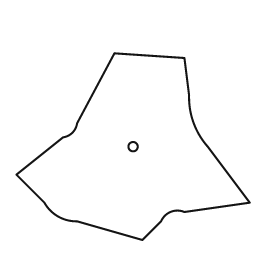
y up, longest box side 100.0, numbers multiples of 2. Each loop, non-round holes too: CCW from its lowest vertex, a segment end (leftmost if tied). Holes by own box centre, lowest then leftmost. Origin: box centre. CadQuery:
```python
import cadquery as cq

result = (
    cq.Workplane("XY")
    .moveTo(4.0, -40.0)
    .lineTo(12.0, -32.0)
    .threePointArc((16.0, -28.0), (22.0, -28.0))
    .lineTo(50.0, -24.0)
    .lineTo(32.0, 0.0)
    .threePointArc((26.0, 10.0), (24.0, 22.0))
    .lineTo(22.0, 38.0)
    .lineTo(-8.0, 40.0)
    .lineTo(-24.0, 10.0)
    .threePointArc((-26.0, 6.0), (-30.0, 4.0))
    .lineTo(-50.0, -12.0)
    .lineTo(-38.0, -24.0)
    .threePointArc((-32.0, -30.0), (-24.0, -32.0))
    .close()
    .moveTo(0.0, 0.0)
    .circle(2.0)
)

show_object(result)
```